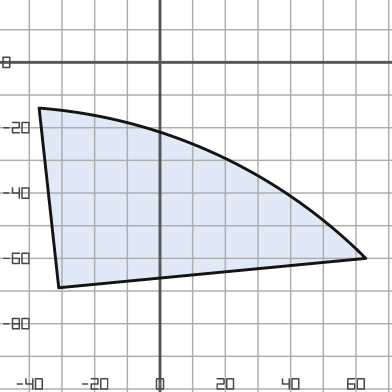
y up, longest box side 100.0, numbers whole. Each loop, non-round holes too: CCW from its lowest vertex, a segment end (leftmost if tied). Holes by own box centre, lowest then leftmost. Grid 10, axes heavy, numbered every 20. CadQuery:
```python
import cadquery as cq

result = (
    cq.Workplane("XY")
    .moveTo(-31.0, -69.0)
    .lineTo(63.0, -60.0)
    .threePointArc((17.0, -28.0), (-37.0, -14.0))
    .close()
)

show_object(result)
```